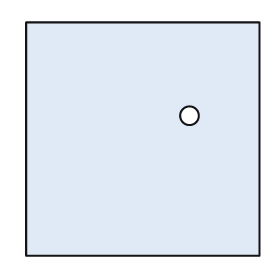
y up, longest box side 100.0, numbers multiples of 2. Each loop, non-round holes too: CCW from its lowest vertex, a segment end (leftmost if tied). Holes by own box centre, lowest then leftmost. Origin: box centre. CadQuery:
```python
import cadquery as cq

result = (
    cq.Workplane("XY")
    .moveTo(-50.0, -50.0)
    .lineTo(50.0, -50.0)
    .lineTo(50.0, 50.0)
    .lineTo(-50.0, 50.0)
    .close()
    .moveTo(20.0, 10.0)
    .circle(4.0)
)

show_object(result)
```